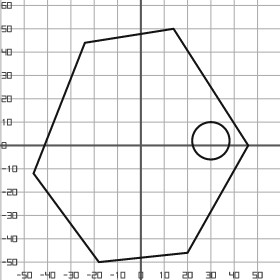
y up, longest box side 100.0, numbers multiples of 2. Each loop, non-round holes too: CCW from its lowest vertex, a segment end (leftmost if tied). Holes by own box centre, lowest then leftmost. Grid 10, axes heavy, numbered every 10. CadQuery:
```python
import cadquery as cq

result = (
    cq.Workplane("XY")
    .moveTo(-18.0, -50.0)
    .lineTo(20.0, -46.0)
    .lineTo(46.0, 0.0)
    .lineTo(14.0, 50.0)
    .lineTo(-24.0, 44.0)
    .lineTo(-46.0, -12.0)
    .close()
    .moveTo(30.0, 2.0)
    .circle(8.0)
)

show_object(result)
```